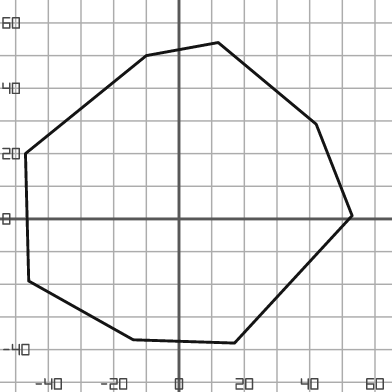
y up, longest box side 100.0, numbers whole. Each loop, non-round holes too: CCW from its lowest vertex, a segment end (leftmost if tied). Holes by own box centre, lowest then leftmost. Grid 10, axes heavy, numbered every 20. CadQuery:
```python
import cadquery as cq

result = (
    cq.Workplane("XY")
    .moveTo(17.0, -38.0)
    .lineTo(53.0, 1.0)
    .lineTo(42.0, 29.0)
    .lineTo(12.0, 54.0)
    .lineTo(-10.0, 50.0)
    .lineTo(-47.0, 20.0)
    .lineTo(-46.0, -19.0)
    .lineTo(-14.0, -37.0)
    .close()
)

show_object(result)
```